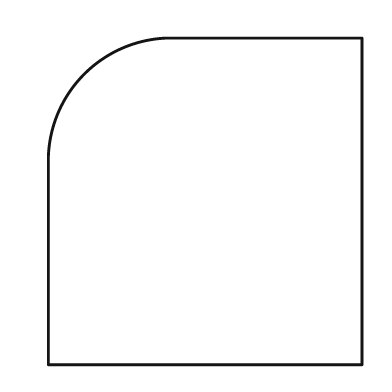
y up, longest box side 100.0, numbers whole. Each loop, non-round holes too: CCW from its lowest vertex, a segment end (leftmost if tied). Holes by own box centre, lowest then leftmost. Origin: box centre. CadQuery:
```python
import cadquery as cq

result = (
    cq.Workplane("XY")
    .moveTo(-48.0, -50.0)
    .lineTo(48.0, -50.0)
    .lineTo(48.0, 50.0)
    .lineTo(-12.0, 50.0)
    .threePointArc((-37.0, 39.0), (-48.0, 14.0))
    .close()
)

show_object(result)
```